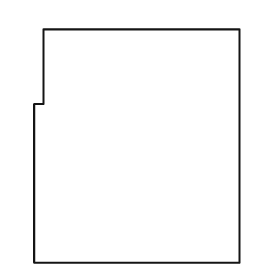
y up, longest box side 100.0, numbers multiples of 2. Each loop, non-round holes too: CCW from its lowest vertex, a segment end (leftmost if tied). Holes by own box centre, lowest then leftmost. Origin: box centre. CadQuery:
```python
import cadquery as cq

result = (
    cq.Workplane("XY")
    .moveTo(-44.0, -50.0)
    .lineTo(44.0, -50.0)
    .lineTo(44.0, 50.0)
    .lineTo(-40.0, 50.0)
    .lineTo(-40.0, 18.0)
    .lineTo(-44.0, 18.0)
    .close()
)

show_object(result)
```